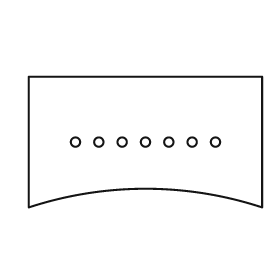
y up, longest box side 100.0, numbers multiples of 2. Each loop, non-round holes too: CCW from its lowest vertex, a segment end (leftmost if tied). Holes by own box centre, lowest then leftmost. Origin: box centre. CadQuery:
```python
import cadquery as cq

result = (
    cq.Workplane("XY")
    .moveTo(-50.0, -28.0)
    .threePointArc((0.0, -20.0), (50.0, -28.0))
    .lineTo(50.0, 28.0)
    .lineTo(-50.0, 28.0)
    .close()
    .moveTo(-30.0, 0.0)
    .circle(2.0)
    .moveTo(-20.0, 0.0)
    .circle(2.0)
    .moveTo(-10.0, 0.0)
    .circle(2.0)
    .moveTo(0.0, 0.0)
    .circle(2.0)
    .moveTo(10.0, 0.0)
    .circle(2.0)
    .moveTo(20.0, 0.0)
    .circle(2.0)
    .moveTo(30.0, 0.0)
    .circle(2.0)
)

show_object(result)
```